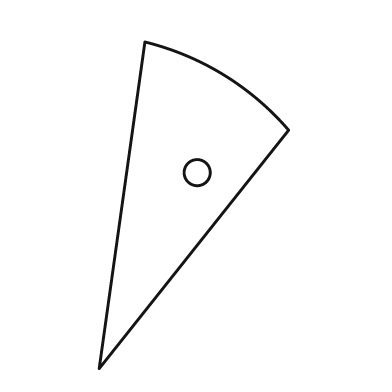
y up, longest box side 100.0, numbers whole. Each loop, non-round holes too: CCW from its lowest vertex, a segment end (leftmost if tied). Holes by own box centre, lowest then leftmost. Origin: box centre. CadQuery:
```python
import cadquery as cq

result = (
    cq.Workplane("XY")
    .moveTo(-29.0, -50.0)
    .lineTo(29.0, 23.0)
    .threePointArc((9.0, 40.0), (-15.0, 50.0))
    .close()
    .moveTo(1.0, 10.0)
    .circle(4.0)
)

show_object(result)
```